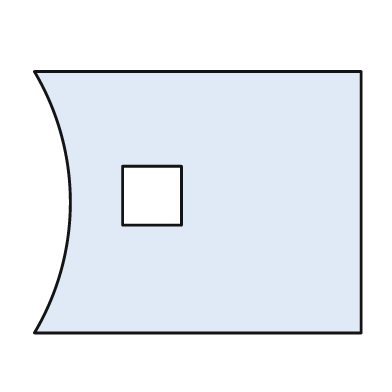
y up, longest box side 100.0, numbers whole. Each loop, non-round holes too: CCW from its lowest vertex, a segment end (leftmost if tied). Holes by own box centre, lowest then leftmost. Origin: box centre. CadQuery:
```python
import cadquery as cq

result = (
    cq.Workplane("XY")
    .moveTo(-50.0, -40.0)
    .lineTo(50.0, -40.0)
    .lineTo(50.0, 40.0)
    .lineTo(-50.0, 40.0)
    .threePointArc((-39.0, 0.0), (-50.0, -40.0))
    .close()
    .moveTo(-23.0, -7.0)
    .lineTo(-5.0, -7.0)
    .lineTo(-5.0, 11.0)
    .lineTo(-23.0, 11.0)
    .close()
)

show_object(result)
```